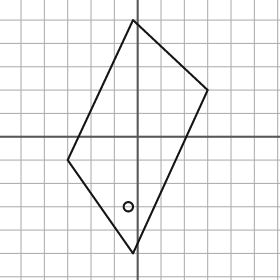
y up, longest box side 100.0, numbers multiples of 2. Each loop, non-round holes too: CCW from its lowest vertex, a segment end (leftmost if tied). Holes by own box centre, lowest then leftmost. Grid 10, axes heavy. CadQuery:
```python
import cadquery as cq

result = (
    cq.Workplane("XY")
    .moveTo(-2.0, -50.0)
    .lineTo(30.0, 20.0)
    .lineTo(-2.0, 50.0)
    .lineTo(-30.0, -10.0)
    .close()
    .moveTo(-4.0, -30.0)
    .circle(2.0)
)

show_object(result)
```